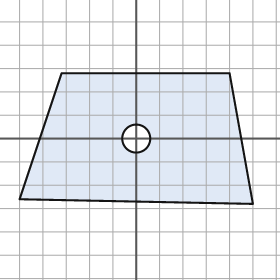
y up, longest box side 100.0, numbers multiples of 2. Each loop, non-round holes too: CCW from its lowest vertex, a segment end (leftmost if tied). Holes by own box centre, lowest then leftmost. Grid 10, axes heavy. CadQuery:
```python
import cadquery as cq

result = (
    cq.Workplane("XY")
    .moveTo(50.0, -28.0)
    .lineTo(40.0, 28.0)
    .lineTo(-32.0, 28.0)
    .lineTo(-50.0, -26.0)
    .close()
    .moveTo(0.0, 0.0)
    .circle(6.0)
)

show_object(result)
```